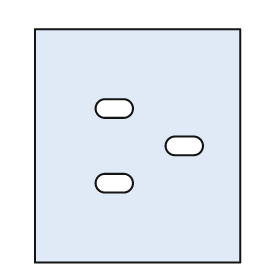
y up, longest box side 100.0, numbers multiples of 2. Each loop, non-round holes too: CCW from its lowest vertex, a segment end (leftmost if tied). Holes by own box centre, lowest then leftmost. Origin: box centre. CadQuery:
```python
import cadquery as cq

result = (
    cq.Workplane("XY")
    .moveTo(-44.0, -50.0)
    .lineTo(44.0, -50.0)
    .lineTo(44.0, 50.0)
    .lineTo(-44.0, 50.0)
    .close()
    .moveTo(-14.0, -20.0)
    .lineTo(-6.0, -20.0)
    .threePointArc((-2.0, -16.0), (-6.0, -12.0))
    .lineTo(-14.0, -12.0)
    .threePointArc((-18.0, -16.0), (-14.0, -20.0))
    .close()
    .moveTo(16.0, -4.0)
    .lineTo(24.0, -4.0)
    .threePointArc((28.0, 0.0), (24.0, 4.0))
    .lineTo(16.0, 4.0)
    .threePointArc((12.0, 0.0), (16.0, -4.0))
    .close()
    .moveTo(-14.0, 12.0)
    .lineTo(-6.0, 12.0)
    .threePointArc((-2.0, 16.0), (-6.0, 20.0))
    .lineTo(-14.0, 20.0)
    .threePointArc((-18.0, 16.0), (-14.0, 12.0))
    .close()
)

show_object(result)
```